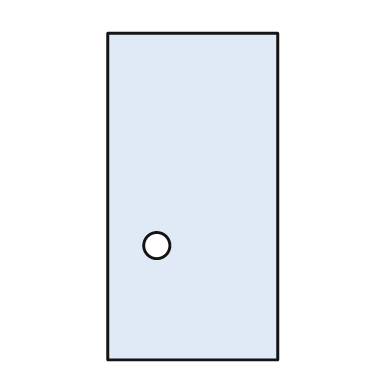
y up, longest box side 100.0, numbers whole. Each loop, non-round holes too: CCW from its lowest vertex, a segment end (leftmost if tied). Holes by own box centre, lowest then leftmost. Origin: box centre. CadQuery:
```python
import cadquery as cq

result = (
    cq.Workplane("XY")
    .moveTo(-26.0, -50.0)
    .lineTo(26.0, -50.0)
    .lineTo(26.0, 50.0)
    .lineTo(-26.0, 50.0)
    .close()
    .moveTo(-11.0, -15.0)
    .circle(4.0)
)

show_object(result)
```